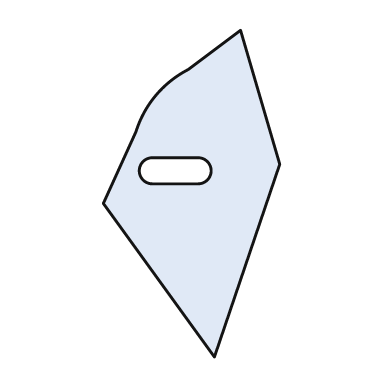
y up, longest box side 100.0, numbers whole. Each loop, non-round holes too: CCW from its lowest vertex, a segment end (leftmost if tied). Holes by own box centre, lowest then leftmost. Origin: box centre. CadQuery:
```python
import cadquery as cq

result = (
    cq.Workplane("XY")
    .moveTo(7.0, -50.0)
    .lineTo(27.0, 9.0)
    .lineTo(15.0, 50.0)
    .lineTo(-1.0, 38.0)
    .threePointArc((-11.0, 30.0), (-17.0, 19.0))
    .lineTo(-27.0, -3.0)
    .close()
    .moveTo(-12.0, 3.0)
    .lineTo(2.0, 3.0)
    .threePointArc((6.0, 7.0), (2.0, 11.0))
    .lineTo(-12.0, 11.0)
    .threePointArc((-16.0, 7.0), (-12.0, 3.0))
    .close()
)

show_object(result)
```